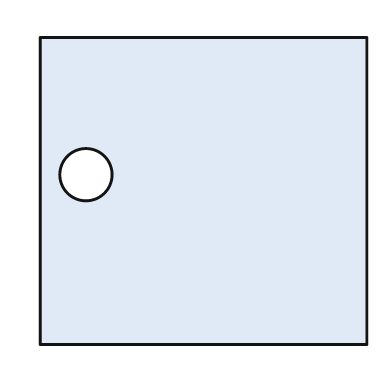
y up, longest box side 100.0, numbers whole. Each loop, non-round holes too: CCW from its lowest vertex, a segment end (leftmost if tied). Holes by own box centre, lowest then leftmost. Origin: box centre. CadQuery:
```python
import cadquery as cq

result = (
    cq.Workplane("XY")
    .moveTo(-50.0, -47.0)
    .lineTo(50.0, -47.0)
    .lineTo(50.0, 47.0)
    .lineTo(-50.0, 47.0)
    .close()
    .moveTo(-36.0, 5.0)
    .circle(8.0)
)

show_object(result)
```